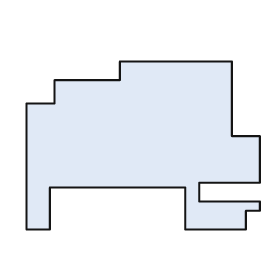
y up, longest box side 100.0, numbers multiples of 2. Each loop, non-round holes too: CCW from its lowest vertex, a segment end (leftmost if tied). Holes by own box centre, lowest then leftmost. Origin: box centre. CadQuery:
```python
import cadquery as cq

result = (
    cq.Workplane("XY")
    .moveTo(-50.0, -36.0)
    .lineTo(-40.0, -36.0)
    .lineTo(-40.0, -18.0)
    .lineTo(18.0, -18.0)
    .lineTo(18.0, -36.0)
    .lineTo(44.0, -36.0)
    .lineTo(44.0, -28.0)
    .lineTo(50.0, -28.0)
    .lineTo(50.0, -24.0)
    .lineTo(24.0, -24.0)
    .lineTo(24.0, -16.0)
    .lineTo(50.0, -16.0)
    .lineTo(50.0, 4.0)
    .lineTo(38.0, 4.0)
    .lineTo(38.0, 36.0)
    .lineTo(-10.0, 36.0)
    .lineTo(-10.0, 28.0)
    .lineTo(-38.0, 28.0)
    .lineTo(-38.0, 18.0)
    .lineTo(-50.0, 18.0)
    .close()
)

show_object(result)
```